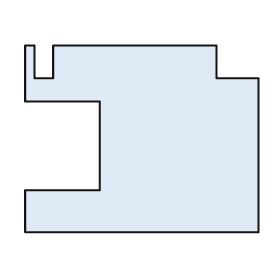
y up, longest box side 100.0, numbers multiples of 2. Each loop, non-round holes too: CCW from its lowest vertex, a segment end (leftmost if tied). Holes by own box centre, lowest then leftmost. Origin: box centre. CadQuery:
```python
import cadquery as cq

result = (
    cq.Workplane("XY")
    .moveTo(-50.0, -40.0)
    .lineTo(50.0, -40.0)
    .lineTo(50.0, 26.0)
    .lineTo(32.0, 26.0)
    .lineTo(32.0, 40.0)
    .lineTo(-38.0, 40.0)
    .lineTo(-38.0, 26.0)
    .lineTo(-46.0, 26.0)
    .lineTo(-46.0, 40.0)
    .lineTo(-50.0, 40.0)
    .lineTo(-50.0, 16.0)
    .lineTo(-18.0, 16.0)
    .lineTo(-18.0, -22.0)
    .lineTo(-50.0, -22.0)
    .close()
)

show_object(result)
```